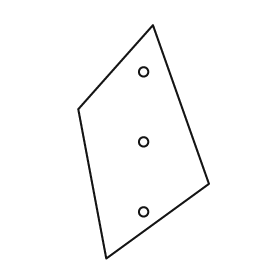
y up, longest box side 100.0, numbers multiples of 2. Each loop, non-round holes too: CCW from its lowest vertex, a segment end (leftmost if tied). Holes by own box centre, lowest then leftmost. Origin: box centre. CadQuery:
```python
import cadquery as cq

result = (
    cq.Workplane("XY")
    .moveTo(-16.0, -50.0)
    .lineTo(28.0, -18.0)
    .lineTo(4.0, 50.0)
    .lineTo(-28.0, 14.0)
    .close()
    .moveTo(0.0, -30.0)
    .circle(2.0)
    .moveTo(0.0, 0.0)
    .circle(2.0)
    .moveTo(0.0, 30.0)
    .circle(2.0)
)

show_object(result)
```